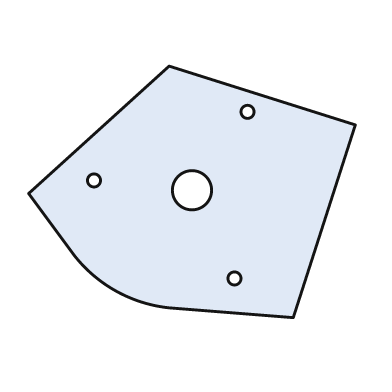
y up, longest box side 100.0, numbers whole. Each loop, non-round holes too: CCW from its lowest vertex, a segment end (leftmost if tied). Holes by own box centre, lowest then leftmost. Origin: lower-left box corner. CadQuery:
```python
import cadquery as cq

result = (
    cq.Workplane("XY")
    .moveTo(81.0, 0.0)
    .lineTo(100.0, 59.0)
    .lineTo(43.0, 77.0)
    .lineTo(0.0, 38.0)
    .lineTo(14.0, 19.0)
    .threePointArc((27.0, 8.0), (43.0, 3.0))
    .close()
    .moveTo(63.0, 12.0)
    .circle(2.0)
    .moveTo(50.0, 39.0)
    .circle(6.0)
    .moveTo(20.0, 42.0)
    .circle(2.0)
    .moveTo(67.0, 63.0)
    .circle(2.0)
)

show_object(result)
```